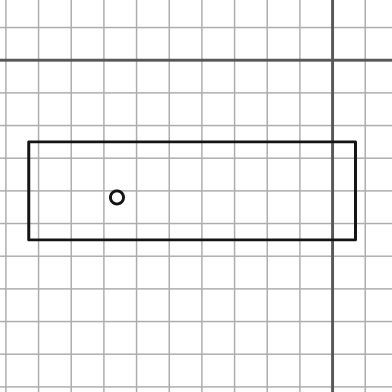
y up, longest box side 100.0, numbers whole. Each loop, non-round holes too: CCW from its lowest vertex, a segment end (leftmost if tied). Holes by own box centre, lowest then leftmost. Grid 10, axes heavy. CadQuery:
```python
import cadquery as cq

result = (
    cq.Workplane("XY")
    .moveTo(-93.0, -55.0)
    .lineTo(7.0, -55.0)
    .lineTo(7.0, -25.0)
    .lineTo(-93.0, -25.0)
    .close()
    .moveTo(-66.0, -42.0)
    .circle(2.0)
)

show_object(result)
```